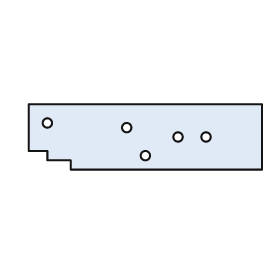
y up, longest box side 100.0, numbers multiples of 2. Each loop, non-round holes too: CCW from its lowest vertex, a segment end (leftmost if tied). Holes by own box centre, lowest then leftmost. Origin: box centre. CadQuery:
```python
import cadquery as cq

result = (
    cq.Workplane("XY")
    .moveTo(-32.0, -14.0)
    .lineTo(50.0, -14.0)
    .lineTo(50.0, 14.0)
    .lineTo(-50.0, 14.0)
    .lineTo(-50.0, -6.0)
    .lineTo(-42.0, -6.0)
    .lineTo(-42.0, -10.0)
    .lineTo(-32.0, -10.0)
    .close()
    .moveTo(0.0, -8.0)
    .circle(2.0)
    .moveTo(14.0, 0.0)
    .circle(2.0)
    .moveTo(26.0, 0.0)
    .circle(2.0)
    .moveTo(-8.0, 4.0)
    .circle(2.0)
    .moveTo(-42.0, 6.0)
    .circle(2.0)
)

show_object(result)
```